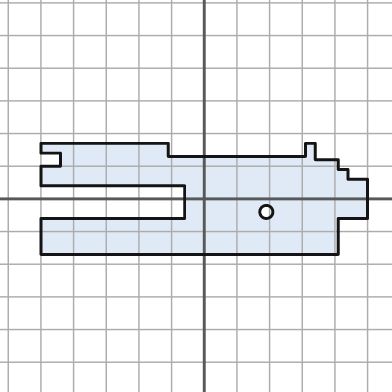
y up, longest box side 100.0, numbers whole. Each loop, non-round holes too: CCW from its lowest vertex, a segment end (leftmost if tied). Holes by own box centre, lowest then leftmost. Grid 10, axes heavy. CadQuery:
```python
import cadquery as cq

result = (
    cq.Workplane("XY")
    .moveTo(-50.0, -17.0)
    .lineTo(41.0, -17.0)
    .lineTo(41.0, -6.0)
    .lineTo(50.0, -6.0)
    .lineTo(50.0, 6.0)
    .lineTo(44.0, 6.0)
    .lineTo(44.0, 9.0)
    .lineTo(41.0, 9.0)
    .lineTo(41.0, 12.0)
    .lineTo(34.0, 12.0)
    .lineTo(34.0, 17.0)
    .lineTo(31.0, 17.0)
    .lineTo(31.0, 13.0)
    .lineTo(-11.0, 13.0)
    .lineTo(-11.0, 17.0)
    .lineTo(-50.0, 17.0)
    .lineTo(-50.0, 14.0)
    .lineTo(-44.0, 14.0)
    .lineTo(-44.0, 10.0)
    .lineTo(-50.0, 10.0)
    .lineTo(-50.0, 4.0)
    .lineTo(-6.0, 4.0)
    .lineTo(-6.0, -6.0)
    .lineTo(-50.0, -6.0)
    .close()
    .moveTo(19.0, -4.0)
    .circle(2.0)
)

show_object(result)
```